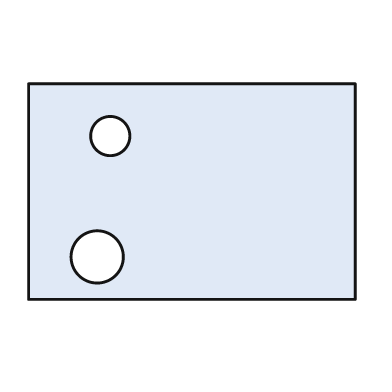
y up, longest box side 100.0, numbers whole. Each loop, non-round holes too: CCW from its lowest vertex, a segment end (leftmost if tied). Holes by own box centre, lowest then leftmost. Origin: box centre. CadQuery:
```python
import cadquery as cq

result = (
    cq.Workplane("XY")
    .moveTo(-50.0, -33.0)
    .lineTo(50.0, -33.0)
    .lineTo(50.0, 33.0)
    .lineTo(-50.0, 33.0)
    .close()
    .moveTo(-29.0, -20.0)
    .circle(8.0)
    .moveTo(-25.0, 17.0)
    .circle(6.0)
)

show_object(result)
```